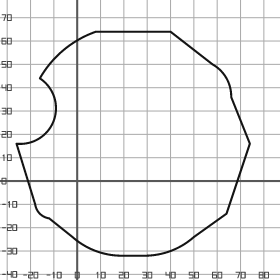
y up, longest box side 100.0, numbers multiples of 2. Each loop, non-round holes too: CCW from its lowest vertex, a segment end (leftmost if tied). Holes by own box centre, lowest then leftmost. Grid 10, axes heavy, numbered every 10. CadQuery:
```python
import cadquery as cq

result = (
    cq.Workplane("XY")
    .moveTo(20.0, -32.0)
    .lineTo(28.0, -32.0)
    .threePointArc((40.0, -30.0), (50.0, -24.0))
    .lineTo(64.0, -14.0)
    .lineTo(74.0, 16.0)
    .lineTo(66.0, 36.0)
    .threePointArc((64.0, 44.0), (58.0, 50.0))
    .lineTo(40.0, 64.0)
    .lineTo(8.0, 64.0)
    .threePointArc((-6.0, 56.0), (-16.0, 44.0))
    .threePointArc((-10.0, 26.0), (-26.0, 16.0))
    .lineTo(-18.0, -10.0)
    .threePointArc((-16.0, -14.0), (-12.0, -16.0))
    .lineTo(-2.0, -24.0)
    .threePointArc((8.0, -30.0), (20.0, -32.0))
    .close()
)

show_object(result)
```